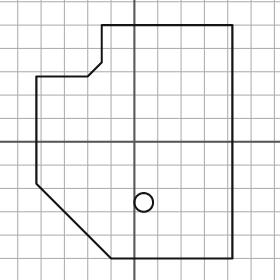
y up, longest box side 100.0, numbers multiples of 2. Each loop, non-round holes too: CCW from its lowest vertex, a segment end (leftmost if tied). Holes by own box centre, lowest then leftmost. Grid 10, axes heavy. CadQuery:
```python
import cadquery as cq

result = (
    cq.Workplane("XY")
    .moveTo(-10.0, -50.0)
    .lineTo(42.0, -50.0)
    .lineTo(42.0, 50.0)
    .lineTo(-14.0, 50.0)
    .lineTo(-14.0, 34.0)
    .lineTo(-20.0, 28.0)
    .lineTo(-42.0, 28.0)
    .lineTo(-42.0, -18.0)
    .close()
    .moveTo(4.0, -26.0)
    .circle(4.0)
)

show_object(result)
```